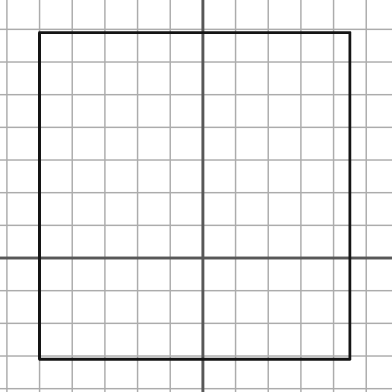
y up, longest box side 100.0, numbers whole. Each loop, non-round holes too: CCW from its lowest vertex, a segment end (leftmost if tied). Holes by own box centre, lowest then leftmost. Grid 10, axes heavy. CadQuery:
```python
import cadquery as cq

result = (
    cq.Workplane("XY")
    .moveTo(-50.0, -31.0)
    .lineTo(45.0, -31.0)
    .lineTo(45.0, 69.0)
    .lineTo(-50.0, 69.0)
    .close()
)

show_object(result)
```